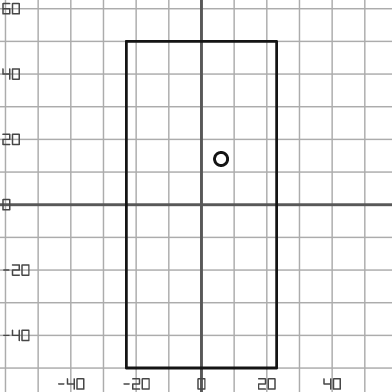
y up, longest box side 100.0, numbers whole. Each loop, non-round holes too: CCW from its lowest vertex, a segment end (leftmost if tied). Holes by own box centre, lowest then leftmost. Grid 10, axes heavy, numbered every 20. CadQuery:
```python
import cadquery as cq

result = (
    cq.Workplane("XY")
    .moveTo(-23.0, -50.0)
    .lineTo(23.0, -50.0)
    .lineTo(23.0, 50.0)
    .lineTo(-23.0, 50.0)
    .close()
    .moveTo(6.0, 14.0)
    .circle(2.0)
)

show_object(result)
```